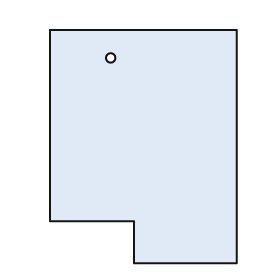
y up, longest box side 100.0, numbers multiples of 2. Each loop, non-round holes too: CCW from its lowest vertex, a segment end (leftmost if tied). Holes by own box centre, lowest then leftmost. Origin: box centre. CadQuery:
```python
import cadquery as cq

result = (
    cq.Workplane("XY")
    .moveTo(-4.0, -50.0)
    .lineTo(40.0, -50.0)
    .lineTo(40.0, 50.0)
    .lineTo(-40.0, 50.0)
    .lineTo(-40.0, -32.0)
    .lineTo(-4.0, -32.0)
    .close()
    .moveTo(-14.0, 38.0)
    .circle(2.0)
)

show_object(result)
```